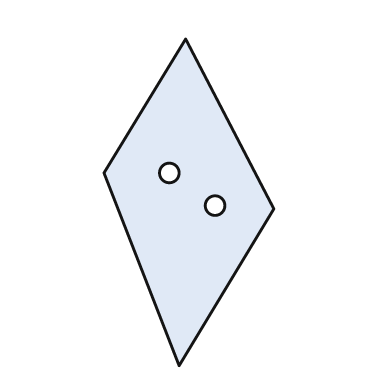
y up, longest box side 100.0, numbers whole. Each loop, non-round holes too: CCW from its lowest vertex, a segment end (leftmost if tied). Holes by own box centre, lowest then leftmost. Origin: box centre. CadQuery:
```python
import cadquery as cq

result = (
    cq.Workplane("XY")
    .moveTo(-3.0, -50.0)
    .lineTo(26.0, -2.0)
    .lineTo(-1.0, 50.0)
    .lineTo(-26.0, 9.0)
    .close()
    .moveTo(8.0, -1.0)
    .circle(3.0)
    .moveTo(-6.0, 9.0)
    .circle(3.0)
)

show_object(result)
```